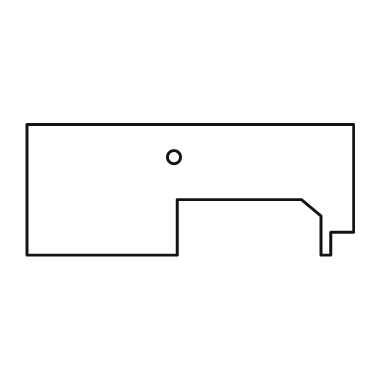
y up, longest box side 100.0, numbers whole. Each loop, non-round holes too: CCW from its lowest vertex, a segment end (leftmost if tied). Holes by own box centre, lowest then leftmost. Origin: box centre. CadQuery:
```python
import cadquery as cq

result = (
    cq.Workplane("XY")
    .moveTo(-50.0, -20.0)
    .lineTo(-4.0, -20.0)
    .lineTo(-4.0, -3.0)
    .lineTo(34.0, -3.0)
    .lineTo(40.0, -8.0)
    .lineTo(40.0, -20.0)
    .lineTo(43.0, -20.0)
    .lineTo(43.0, -13.0)
    .lineTo(50.0, -13.0)
    .lineTo(50.0, 20.0)
    .lineTo(-50.0, 20.0)
    .close()
    .moveTo(-5.0, 10.0)
    .circle(2.0)
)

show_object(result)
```